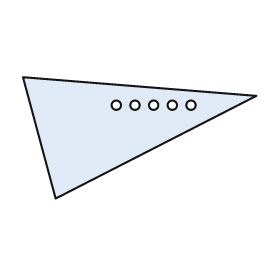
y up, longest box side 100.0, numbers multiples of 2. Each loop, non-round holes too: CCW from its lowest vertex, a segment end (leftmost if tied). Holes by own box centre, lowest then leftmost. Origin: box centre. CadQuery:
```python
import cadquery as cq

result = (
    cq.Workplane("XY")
    .moveTo(-36.0, -26.0)
    .lineTo(50.0, 18.0)
    .lineTo(-50.0, 26.0)
    .close()
    .moveTo(-10.0, 14.0)
    .circle(2.0)
    .moveTo(-2.0, 14.0)
    .circle(2.0)
    .moveTo(6.0, 14.0)
    .circle(2.0)
    .moveTo(14.0, 14.0)
    .circle(2.0)
    .moveTo(22.0, 14.0)
    .circle(2.0)
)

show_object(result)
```